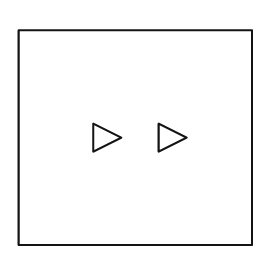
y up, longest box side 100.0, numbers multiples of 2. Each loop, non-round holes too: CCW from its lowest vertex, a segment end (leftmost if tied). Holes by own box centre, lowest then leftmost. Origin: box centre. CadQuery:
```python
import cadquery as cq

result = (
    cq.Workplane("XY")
    .moveTo(-50.0, -46.0)
    .lineTo(50.0, -46.0)
    .lineTo(50.0, 46.0)
    .lineTo(-50.0, 46.0)
    .close()
    .moveTo(-18.0, -6.0)
    .lineTo(-6.0, 0.0)
    .lineTo(-18.0, 6.0)
    .close()
    .moveTo(10.0, -6.0)
    .lineTo(22.0, 0.0)
    .lineTo(10.0, 6.0)
    .close()
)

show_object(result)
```